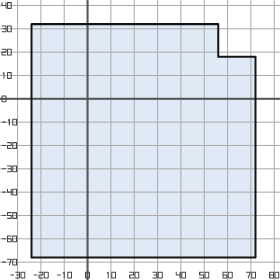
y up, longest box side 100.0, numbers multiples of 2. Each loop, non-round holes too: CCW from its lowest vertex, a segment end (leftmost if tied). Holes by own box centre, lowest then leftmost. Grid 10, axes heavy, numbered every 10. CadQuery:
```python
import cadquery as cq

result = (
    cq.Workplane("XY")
    .moveTo(-24.0, -68.0)
    .lineTo(72.0, -68.0)
    .lineTo(72.0, 18.0)
    .lineTo(56.0, 18.0)
    .lineTo(56.0, 32.0)
    .lineTo(-24.0, 32.0)
    .close()
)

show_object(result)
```